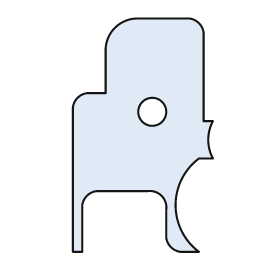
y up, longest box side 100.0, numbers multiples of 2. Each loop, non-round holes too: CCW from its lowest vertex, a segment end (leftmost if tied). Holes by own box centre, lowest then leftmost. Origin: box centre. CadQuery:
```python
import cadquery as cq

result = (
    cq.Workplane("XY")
    .moveTo(-30.0, -50.0)
    .lineTo(-26.0, -50.0)
    .lineTo(-26.0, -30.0)
    .threePointArc((-24.0, -26.0), (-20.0, -24.0))
    .lineTo(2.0, -24.0)
    .threePointArc((8.0, -26.0), (10.0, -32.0))
    .lineTo(10.0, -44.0)
    .threePointArc((12.0, -48.0), (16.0, -50.0))
    .lineTo(24.0, -50.0)
    .threePointArc((14.0, -30.0), (24.0, -10.0))
    .lineTo(30.0, -10.0)
    .threePointArc((28.0, -2.0), (30.0, 6.0))
    .lineTo(26.0, 6.0)
    .lineTo(26.0, 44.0)
    .threePointArc((24.0, 48.0), (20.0, 50.0))
    .lineTo(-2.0, 50.0)
    .threePointArc((-12.0, 46.0), (-16.0, 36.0))
    .lineTo(-16.0, 18.0)
    .lineTo(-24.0, 18.0)
    .threePointArc((-28.0, 16.0), (-30.0, 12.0))
    .close()
    .moveTo(4.0, 10.0)
    .circle(6.0)
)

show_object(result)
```